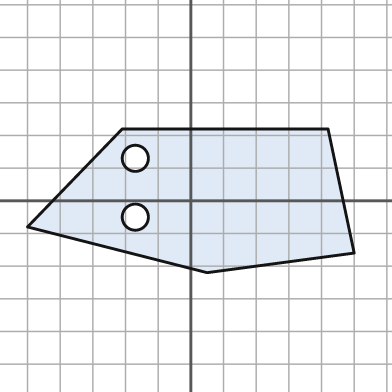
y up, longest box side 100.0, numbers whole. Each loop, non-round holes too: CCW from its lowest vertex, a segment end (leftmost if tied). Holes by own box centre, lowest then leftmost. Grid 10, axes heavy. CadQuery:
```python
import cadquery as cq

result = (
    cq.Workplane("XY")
    .moveTo(5.0, -22.0)
    .lineTo(50.0, -16.0)
    .lineTo(42.0, 22.0)
    .lineTo(-21.0, 22.0)
    .lineTo(-50.0, -8.0)
    .close()
    .moveTo(-17.0, -5.0)
    .circle(4.0)
    .moveTo(-17.0, 13.0)
    .circle(4.0)
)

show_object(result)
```